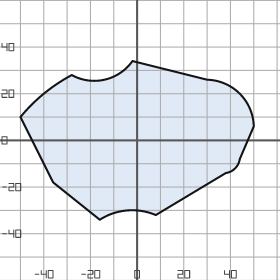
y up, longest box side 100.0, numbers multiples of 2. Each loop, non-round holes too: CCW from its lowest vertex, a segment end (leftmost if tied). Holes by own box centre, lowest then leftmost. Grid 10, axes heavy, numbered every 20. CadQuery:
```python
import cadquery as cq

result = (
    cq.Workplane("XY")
    .moveTo(-16.0, -34.0)
    .threePointArc((-4.0, -30.0), (8.0, -32.0))
    .lineTo(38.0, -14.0)
    .threePointArc((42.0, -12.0), (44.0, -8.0))
    .lineTo(50.0, 6.0)
    .threePointArc((44.0, 20.0), (30.0, 26.0))
    .lineTo(-2.0, 34.0)
    .threePointArc((-14.0, 26.0), (-28.0, 28.0))
    .threePointArc((-40.0, 20.0), (-50.0, 10.0))
    .lineTo(-36.0, -18.0)
    .close()
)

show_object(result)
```